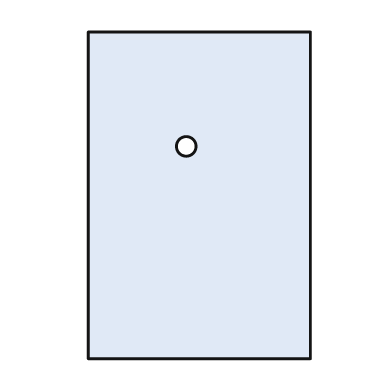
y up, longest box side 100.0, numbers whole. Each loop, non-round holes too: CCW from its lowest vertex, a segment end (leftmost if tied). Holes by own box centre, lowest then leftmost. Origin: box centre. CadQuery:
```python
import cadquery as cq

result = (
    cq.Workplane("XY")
    .moveTo(-34.0, -50.0)
    .lineTo(34.0, -50.0)
    .lineTo(34.0, 50.0)
    .lineTo(-34.0, 50.0)
    .close()
    .moveTo(-4.0, 15.0)
    .circle(3.0)
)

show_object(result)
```